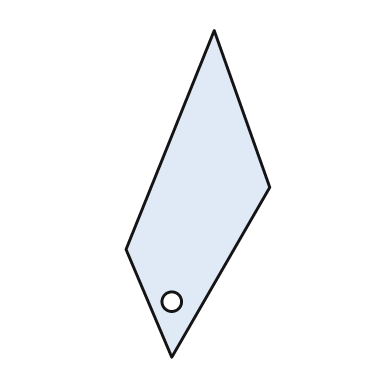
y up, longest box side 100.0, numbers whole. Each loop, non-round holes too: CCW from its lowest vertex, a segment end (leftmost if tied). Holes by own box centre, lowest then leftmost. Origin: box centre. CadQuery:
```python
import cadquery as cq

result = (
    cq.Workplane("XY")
    .moveTo(-8.0, -50.0)
    .lineTo(22.0, 2.0)
    .lineTo(5.0, 50.0)
    .lineTo(-22.0, -17.0)
    .close()
    .moveTo(-8.0, -33.0)
    .circle(3.0)
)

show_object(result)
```